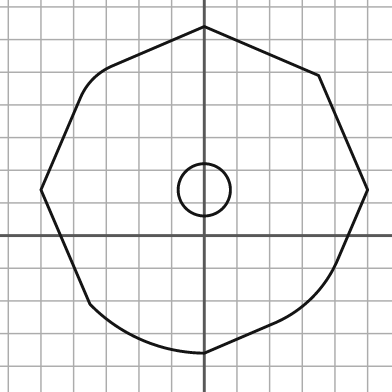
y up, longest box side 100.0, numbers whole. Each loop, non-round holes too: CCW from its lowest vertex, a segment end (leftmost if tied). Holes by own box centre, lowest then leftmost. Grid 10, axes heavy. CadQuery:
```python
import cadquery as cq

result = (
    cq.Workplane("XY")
    .moveTo(0.0, -36.0)
    .lineTo(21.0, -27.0)
    .threePointArc((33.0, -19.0), (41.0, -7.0))
    .lineTo(50.0, 14.0)
    .lineTo(35.0, 49.0)
    .lineTo(0.0, 64.0)
    .lineTo(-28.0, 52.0)
    .threePointArc((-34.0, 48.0), (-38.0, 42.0))
    .lineTo(-50.0, 14.0)
    .lineTo(-35.0, -21.0)
    .threePointArc((-19.0, -32.0), (0.0, -36.0))
    .close()
    .moveTo(0.0, 14.0)
    .circle(8.0)
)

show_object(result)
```